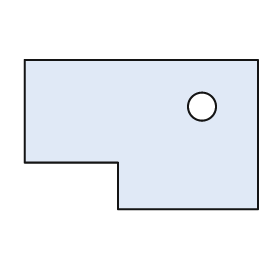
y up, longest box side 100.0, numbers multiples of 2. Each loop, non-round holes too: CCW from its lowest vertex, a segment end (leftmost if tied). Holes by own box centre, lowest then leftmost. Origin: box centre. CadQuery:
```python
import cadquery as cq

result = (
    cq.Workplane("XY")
    .moveTo(-10.0, -32.0)
    .lineTo(50.0, -32.0)
    .lineTo(50.0, 32.0)
    .lineTo(-50.0, 32.0)
    .lineTo(-50.0, -12.0)
    .lineTo(-10.0, -12.0)
    .close()
    .moveTo(26.0, 12.0)
    .circle(6.0)
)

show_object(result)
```